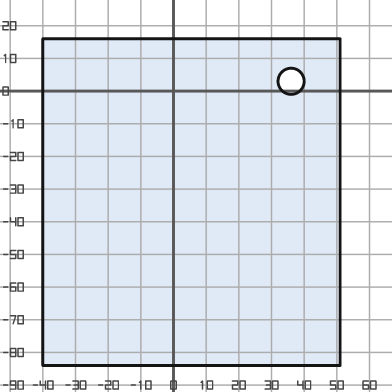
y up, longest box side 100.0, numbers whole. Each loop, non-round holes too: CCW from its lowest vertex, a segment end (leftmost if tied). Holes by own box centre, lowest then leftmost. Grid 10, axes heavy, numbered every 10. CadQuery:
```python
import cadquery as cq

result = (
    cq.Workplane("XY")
    .moveTo(-40.0, -84.0)
    .lineTo(51.0, -84.0)
    .lineTo(51.0, 16.0)
    .lineTo(-40.0, 16.0)
    .close()
    .moveTo(36.0, 3.0)
    .circle(4.0)
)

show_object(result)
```